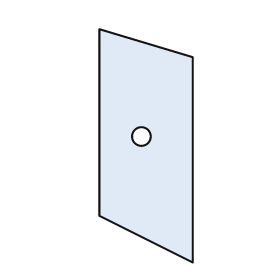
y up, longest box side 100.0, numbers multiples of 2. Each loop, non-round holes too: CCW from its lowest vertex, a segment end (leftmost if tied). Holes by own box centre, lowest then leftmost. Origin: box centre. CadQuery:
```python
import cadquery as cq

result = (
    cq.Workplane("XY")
    .moveTo(20.0, -50.0)
    .lineTo(20.0, 38.0)
    .lineTo(-20.0, 50.0)
    .lineTo(-20.0, -30.0)
    .close()
    .moveTo(-2.0, 4.0)
    .circle(4.0)
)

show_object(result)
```